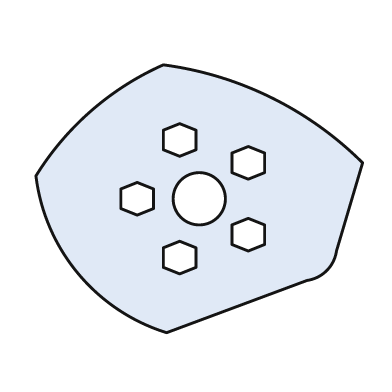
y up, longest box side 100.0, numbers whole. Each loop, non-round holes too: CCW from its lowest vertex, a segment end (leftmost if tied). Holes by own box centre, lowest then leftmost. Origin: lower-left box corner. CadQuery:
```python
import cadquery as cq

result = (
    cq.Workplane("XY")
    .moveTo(40.0, 0.0)
    .lineTo(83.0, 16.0)
    .threePointArc((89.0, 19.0), (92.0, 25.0))
    .lineTo(100.0, 52.0)
    .threePointArc((72.0, 72.0), (39.0, 82.0))
    .threePointArc((17.0, 68.0), (0.0, 48.0))
    .threePointArc((13.0, 18.0), (40.0, 0.0))
    .close()
    .moveTo(44.0, 18.0)
    .lineTo(49.0, 20.0)
    .lineTo(49.0, 26.0)
    .lineTo(44.0, 28.0)
    .lineTo(39.0, 26.0)
    .lineTo(39.0, 20.0)
    .close()
    .moveTo(65.0, 25.0)
    .lineTo(70.0, 27.0)
    .lineTo(70.0, 33.0)
    .lineTo(65.0, 35.0)
    .lineTo(60.0, 33.0)
    .lineTo(60.0, 27.0)
    .close()
    .moveTo(31.0, 36.0)
    .lineTo(36.0, 38.0)
    .lineTo(36.0, 44.0)
    .lineTo(31.0, 46.0)
    .lineTo(26.0, 44.0)
    .lineTo(26.0, 38.0)
    .close()
    .moveTo(50.0, 41.0)
    .circle(8.0)
    .moveTo(65.0, 47.0)
    .lineTo(70.0, 49.0)
    .lineTo(70.0, 55.0)
    .lineTo(65.0, 57.0)
    .lineTo(60.0, 55.0)
    .lineTo(60.0, 49.0)
    .close()
    .moveTo(44.0, 54.0)
    .lineTo(49.0, 56.0)
    .lineTo(49.0, 62.0)
    .lineTo(44.0, 64.0)
    .lineTo(39.0, 62.0)
    .lineTo(39.0, 56.0)
    .close()
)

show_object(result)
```